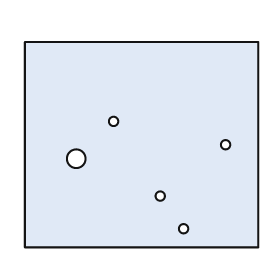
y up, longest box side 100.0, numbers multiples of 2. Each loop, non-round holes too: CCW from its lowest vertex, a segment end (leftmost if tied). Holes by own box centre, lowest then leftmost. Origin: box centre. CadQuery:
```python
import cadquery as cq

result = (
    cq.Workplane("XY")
    .moveTo(-50.0, -44.0)
    .lineTo(50.0, -44.0)
    .lineTo(50.0, 44.0)
    .lineTo(-50.0, 44.0)
    .close()
    .moveTo(18.0, -36.0)
    .circle(2.0)
    .moveTo(8.0, -22.0)
    .circle(2.0)
    .moveTo(-28.0, -6.0)
    .circle(4.0)
    .moveTo(36.0, 0.0)
    .circle(2.0)
    .moveTo(-12.0, 10.0)
    .circle(2.0)
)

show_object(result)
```